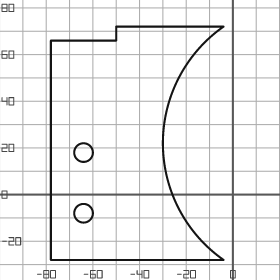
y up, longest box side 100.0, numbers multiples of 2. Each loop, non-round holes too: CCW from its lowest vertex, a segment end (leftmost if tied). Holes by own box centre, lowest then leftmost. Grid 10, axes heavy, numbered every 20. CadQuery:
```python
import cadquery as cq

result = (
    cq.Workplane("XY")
    .moveTo(-78.0, -28.0)
    .lineTo(-4.0, -28.0)
    .threePointArc((-30.0, 22.0), (-4.0, 72.0))
    .lineTo(-50.0, 72.0)
    .lineTo(-50.0, 66.0)
    .lineTo(-78.0, 66.0)
    .close()
    .moveTo(-64.0, -8.0)
    .circle(4.0)
    .moveTo(-64.0, 18.0)
    .circle(4.0)
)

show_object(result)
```